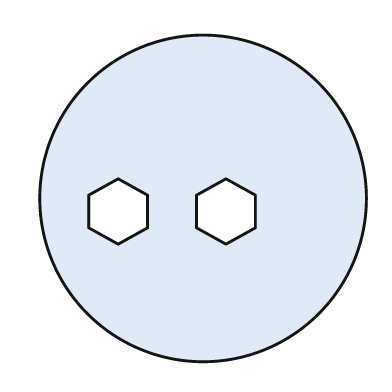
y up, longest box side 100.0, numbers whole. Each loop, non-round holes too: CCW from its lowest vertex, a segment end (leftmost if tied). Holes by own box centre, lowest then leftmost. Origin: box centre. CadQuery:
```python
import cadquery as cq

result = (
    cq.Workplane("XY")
    .moveTo(0.0, 0.0)
    .circle(50.0)
    .moveTo(-26.0, -14.0)
    .lineTo(-17.0, -9.0)
    .lineTo(-17.0, 1.0)
    .lineTo(-26.0, 6.0)
    .lineTo(-35.0, 1.0)
    .lineTo(-35.0, -9.0)
    .close()
    .moveTo(7.0, -14.0)
    .lineTo(16.0, -9.0)
    .lineTo(16.0, 1.0)
    .lineTo(7.0, 6.0)
    .lineTo(-2.0, 1.0)
    .lineTo(-2.0, -9.0)
    .close()
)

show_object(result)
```